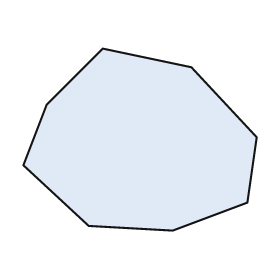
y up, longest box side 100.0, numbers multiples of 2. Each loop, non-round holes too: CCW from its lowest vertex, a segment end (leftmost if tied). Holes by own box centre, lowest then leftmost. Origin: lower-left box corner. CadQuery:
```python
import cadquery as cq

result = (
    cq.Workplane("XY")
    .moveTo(64.0, 0.0)
    .lineTo(96.0, 12.0)
    .lineTo(100.0, 40.0)
    .lineTo(72.0, 70.0)
    .lineTo(34.0, 78.0)
    .lineTo(10.0, 54.0)
    .lineTo(0.0, 28.0)
    .lineTo(28.0, 2.0)
    .close()
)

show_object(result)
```